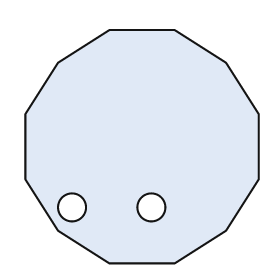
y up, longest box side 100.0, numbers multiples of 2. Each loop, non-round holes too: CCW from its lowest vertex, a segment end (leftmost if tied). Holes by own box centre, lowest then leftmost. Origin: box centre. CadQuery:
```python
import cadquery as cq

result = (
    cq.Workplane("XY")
    .moveTo(-14.0, -50.0)
    .lineTo(14.0, -50.0)
    .lineTo(36.0, -36.0)
    .lineTo(50.0, -14.0)
    .lineTo(50.0, 14.0)
    .lineTo(36.0, 36.0)
    .lineTo(14.0, 50.0)
    .lineTo(-14.0, 50.0)
    .lineTo(-36.0, 36.0)
    .lineTo(-50.0, 14.0)
    .lineTo(-50.0, -14.0)
    .lineTo(-36.0, -36.0)
    .close()
    .moveTo(-30.0, -26.0)
    .circle(6.0)
    .moveTo(4.0, -26.0)
    .circle(6.0)
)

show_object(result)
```